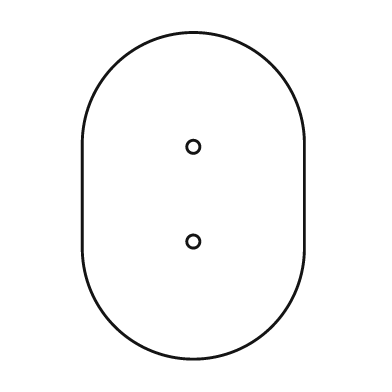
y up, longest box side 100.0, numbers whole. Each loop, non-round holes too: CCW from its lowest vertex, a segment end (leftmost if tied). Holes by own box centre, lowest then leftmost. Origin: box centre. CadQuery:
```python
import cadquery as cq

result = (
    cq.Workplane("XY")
    .moveTo(-34.0, -16.0)
    .threePointArc((0.0, -50.0), (34.0, -16.0))
    .lineTo(34.0, 16.0)
    .threePointArc((0.0, 50.0), (-34.0, 16.0))
    .close()
    .moveTo(0.0, -14.0)
    .circle(2.0)
    .moveTo(0.0, 15.0)
    .circle(2.0)
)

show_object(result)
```